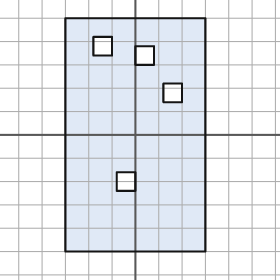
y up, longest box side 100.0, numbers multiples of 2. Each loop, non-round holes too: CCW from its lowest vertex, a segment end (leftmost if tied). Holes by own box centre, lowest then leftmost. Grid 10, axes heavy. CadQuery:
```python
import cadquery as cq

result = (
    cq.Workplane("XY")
    .moveTo(-30.0, -50.0)
    .lineTo(30.0, -50.0)
    .lineTo(30.0, 50.0)
    .lineTo(-30.0, 50.0)
    .close()
    .moveTo(-8.0, -24.0)
    .lineTo(0.0, -24.0)
    .lineTo(0.0, -16.0)
    .lineTo(-8.0, -16.0)
    .close()
    .moveTo(12.0, 14.0)
    .lineTo(20.0, 14.0)
    .lineTo(20.0, 22.0)
    .lineTo(12.0, 22.0)
    .close()
    .moveTo(0.0, 30.0)
    .lineTo(8.0, 30.0)
    .lineTo(8.0, 38.0)
    .lineTo(0.0, 38.0)
    .close()
    .moveTo(-18.0, 34.0)
    .lineTo(-10.0, 34.0)
    .lineTo(-10.0, 42.0)
    .lineTo(-18.0, 42.0)
    .close()
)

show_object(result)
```